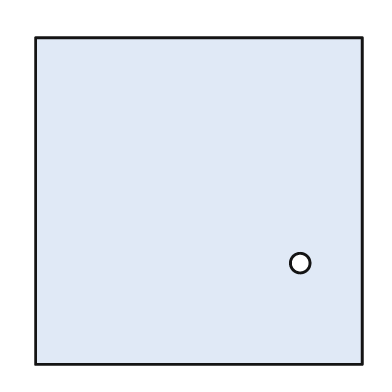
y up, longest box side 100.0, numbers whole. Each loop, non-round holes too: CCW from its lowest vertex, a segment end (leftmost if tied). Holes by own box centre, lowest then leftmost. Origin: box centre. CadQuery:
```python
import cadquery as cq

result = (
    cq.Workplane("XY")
    .moveTo(-50.0, -50.0)
    .lineTo(50.0, -50.0)
    .lineTo(50.0, 50.0)
    .lineTo(-50.0, 50.0)
    .close()
    .moveTo(31.0, -19.0)
    .circle(3.0)
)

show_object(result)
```